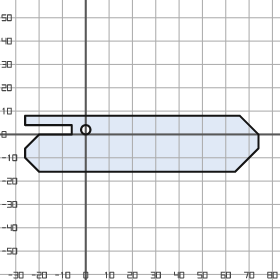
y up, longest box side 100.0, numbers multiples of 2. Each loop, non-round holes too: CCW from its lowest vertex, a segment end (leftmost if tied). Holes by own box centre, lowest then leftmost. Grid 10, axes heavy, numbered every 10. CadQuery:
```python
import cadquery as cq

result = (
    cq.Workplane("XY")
    .moveTo(-20.0, -16.0)
    .lineTo(64.0, -16.0)
    .lineTo(74.0, -6.0)
    .lineTo(74.0, 0.0)
    .lineTo(66.0, 8.0)
    .lineTo(-26.0, 8.0)
    .lineTo(-26.0, 4.0)
    .lineTo(-6.0, 4.0)
    .lineTo(-6.0, 0.0)
    .lineTo(-20.0, 0.0)
    .lineTo(-26.0, -6.0)
    .lineTo(-26.0, -10.0)
    .close()
    .moveTo(0.0, 2.0)
    .circle(2.0)
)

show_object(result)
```